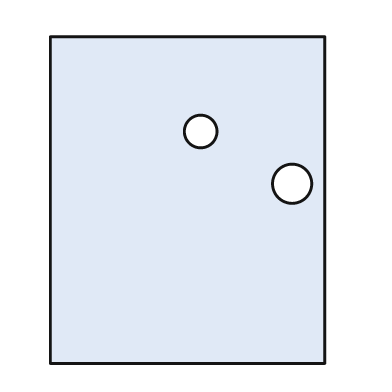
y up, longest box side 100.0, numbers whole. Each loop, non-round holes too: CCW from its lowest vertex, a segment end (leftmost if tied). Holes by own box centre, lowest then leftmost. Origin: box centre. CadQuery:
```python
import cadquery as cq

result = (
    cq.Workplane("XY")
    .moveTo(-42.0, -50.0)
    .lineTo(42.0, -50.0)
    .lineTo(42.0, 50.0)
    .lineTo(-42.0, 50.0)
    .close()
    .moveTo(32.0, 5.0)
    .circle(6.0)
    .moveTo(4.0, 21.0)
    .circle(5.0)
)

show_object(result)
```